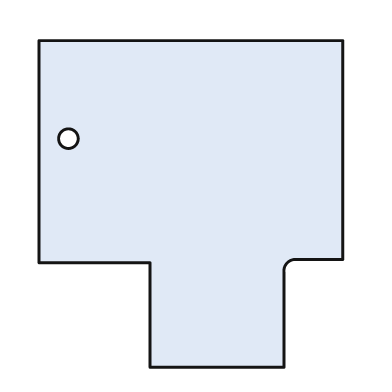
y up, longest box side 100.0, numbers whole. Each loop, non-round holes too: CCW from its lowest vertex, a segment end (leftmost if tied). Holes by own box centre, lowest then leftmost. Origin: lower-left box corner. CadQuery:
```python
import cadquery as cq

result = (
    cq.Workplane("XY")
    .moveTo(34.0, 0.0)
    .lineTo(75.0, 0.0)
    .lineTo(75.0, 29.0)
    .threePointArc((76.0, 32.0), (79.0, 33.0))
    .lineTo(93.0, 33.0)
    .lineTo(93.0, 100.0)
    .lineTo(0.0, 100.0)
    .lineTo(0.0, 32.0)
    .lineTo(34.0, 32.0)
    .close()
    .moveTo(9.0, 70.0)
    .circle(3.0)
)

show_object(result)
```